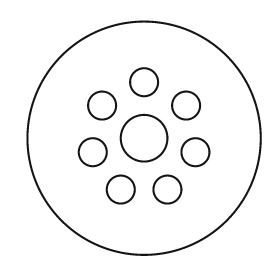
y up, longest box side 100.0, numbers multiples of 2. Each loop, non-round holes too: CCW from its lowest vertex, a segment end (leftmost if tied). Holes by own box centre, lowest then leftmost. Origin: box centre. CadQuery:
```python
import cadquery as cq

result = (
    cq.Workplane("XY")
    .moveTo(0.0, 0.0)
    .circle(50.0)
    .moveTo(-10.0, -22.0)
    .circle(6.0)
    .moveTo(10.0, -22.0)
    .circle(6.0)
    .moveTo(-22.0, -6.0)
    .circle(6.0)
    .moveTo(22.0, -6.0)
    .circle(6.0)
    .moveTo(0.0, 0.0)
    .circle(10.0)
    .moveTo(-18.0, 14.0)
    .circle(6.0)
    .moveTo(18.0, 14.0)
    .circle(6.0)
    .moveTo(0.0, 24.0)
    .circle(6.0)
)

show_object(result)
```